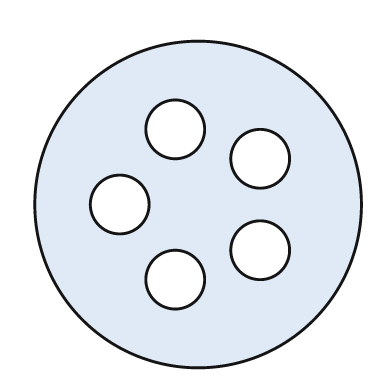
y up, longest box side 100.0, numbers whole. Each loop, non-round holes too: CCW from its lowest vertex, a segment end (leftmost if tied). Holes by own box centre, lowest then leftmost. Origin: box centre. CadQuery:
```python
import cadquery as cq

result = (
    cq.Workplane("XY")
    .moveTo(0.0, 0.0)
    .circle(50.0)
    .moveTo(-7.0, -23.0)
    .circle(9.0)
    .moveTo(19.0, -14.0)
    .circle(9.0)
    .moveTo(-24.0, 0.0)
    .circle(9.0)
    .moveTo(19.0, 14.0)
    .circle(9.0)
    .moveTo(-7.0, 23.0)
    .circle(9.0)
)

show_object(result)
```